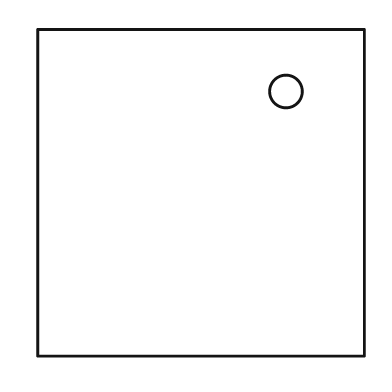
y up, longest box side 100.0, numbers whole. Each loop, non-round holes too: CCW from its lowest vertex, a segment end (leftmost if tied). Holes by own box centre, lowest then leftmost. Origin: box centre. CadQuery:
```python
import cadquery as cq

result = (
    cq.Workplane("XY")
    .moveTo(-50.0, -50.0)
    .lineTo(50.0, -50.0)
    .lineTo(50.0, 50.0)
    .lineTo(-50.0, 50.0)
    .close()
    .moveTo(26.0, 31.0)
    .circle(5.0)
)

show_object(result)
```